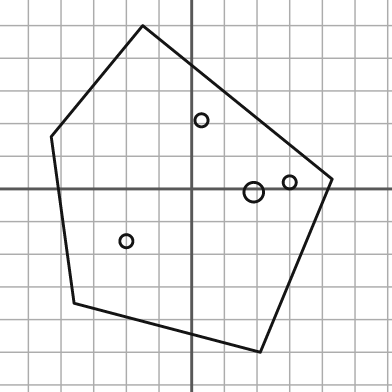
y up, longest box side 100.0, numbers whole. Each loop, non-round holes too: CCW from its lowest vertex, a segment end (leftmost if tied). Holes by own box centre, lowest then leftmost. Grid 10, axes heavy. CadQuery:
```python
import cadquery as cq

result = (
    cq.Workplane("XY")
    .moveTo(21.0, -50.0)
    .lineTo(43.0, 3.0)
    .lineTo(-15.0, 50.0)
    .lineTo(-43.0, 16.0)
    .lineTo(-36.0, -35.0)
    .close()
    .moveTo(-20.0, -16.0)
    .circle(2.0)
    .moveTo(19.0, -1.0)
    .circle(3.0)
    .moveTo(30.0, 2.0)
    .circle(2.0)
    .moveTo(3.0, 21.0)
    .circle(2.0)
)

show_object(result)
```